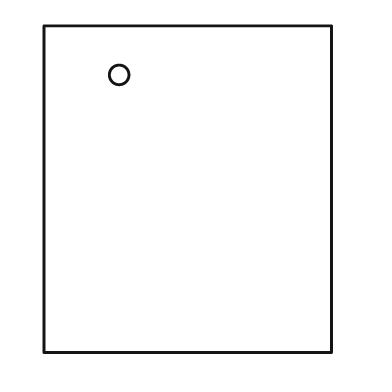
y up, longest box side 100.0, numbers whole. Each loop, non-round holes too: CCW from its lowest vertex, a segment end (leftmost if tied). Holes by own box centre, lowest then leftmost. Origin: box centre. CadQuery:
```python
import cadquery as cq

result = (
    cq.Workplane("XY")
    .moveTo(-44.0, -50.0)
    .lineTo(44.0, -50.0)
    .lineTo(44.0, 50.0)
    .lineTo(-44.0, 50.0)
    .close()
    .moveTo(-21.0, 35.0)
    .circle(3.0)
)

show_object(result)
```